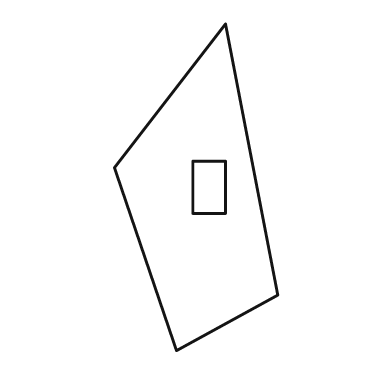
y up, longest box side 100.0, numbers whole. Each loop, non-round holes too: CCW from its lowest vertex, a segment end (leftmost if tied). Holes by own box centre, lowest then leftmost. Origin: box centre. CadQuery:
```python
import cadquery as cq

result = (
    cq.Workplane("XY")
    .moveTo(-6.0, -50.0)
    .lineTo(25.0, -33.0)
    .lineTo(9.0, 50.0)
    .lineTo(-25.0, 6.0)
    .close()
    .moveTo(-1.0, -8.0)
    .lineTo(9.0, -8.0)
    .lineTo(9.0, 8.0)
    .lineTo(-1.0, 8.0)
    .close()
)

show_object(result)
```